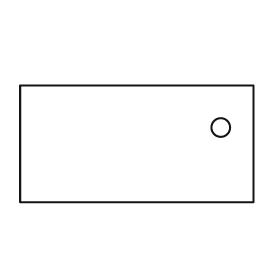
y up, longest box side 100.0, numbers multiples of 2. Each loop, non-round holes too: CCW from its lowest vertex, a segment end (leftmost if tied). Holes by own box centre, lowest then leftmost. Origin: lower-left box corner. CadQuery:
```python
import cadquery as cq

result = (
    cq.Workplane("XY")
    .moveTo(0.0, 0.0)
    .lineTo(100.0, 0.0)
    .lineTo(100.0, 50.0)
    .lineTo(0.0, 50.0)
    .close()
    .moveTo(86.0, 32.0)
    .circle(4.0)
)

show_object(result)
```